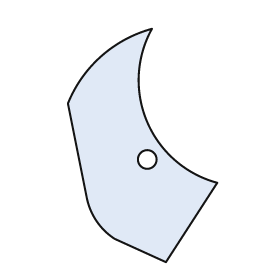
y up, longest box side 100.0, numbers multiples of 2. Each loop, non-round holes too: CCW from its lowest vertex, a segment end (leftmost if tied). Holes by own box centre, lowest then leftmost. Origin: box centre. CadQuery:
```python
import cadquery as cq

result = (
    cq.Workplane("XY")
    .moveTo(10.0, -50.0)
    .lineTo(32.0, -16.0)
    .threePointArc((2.0, 10.0), (4.0, 50.0))
    .threePointArc((-18.0, 38.0), (-32.0, 18.0))
    .lineTo(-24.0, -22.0)
    .threePointArc((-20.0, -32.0), (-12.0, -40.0))
    .close()
    .moveTo(2.0, -6.0)
    .circle(4.0)
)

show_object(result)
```